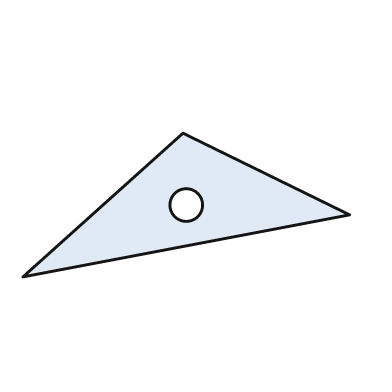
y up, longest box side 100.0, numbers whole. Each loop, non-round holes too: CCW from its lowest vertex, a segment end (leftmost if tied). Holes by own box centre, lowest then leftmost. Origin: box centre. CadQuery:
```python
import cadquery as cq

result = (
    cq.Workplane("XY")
    .moveTo(-50.0, -22.0)
    .lineTo(50.0, -3.0)
    .lineTo(-1.0, 22.0)
    .close()
    .moveTo(0.0, 0.0)
    .circle(5.0)
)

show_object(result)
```